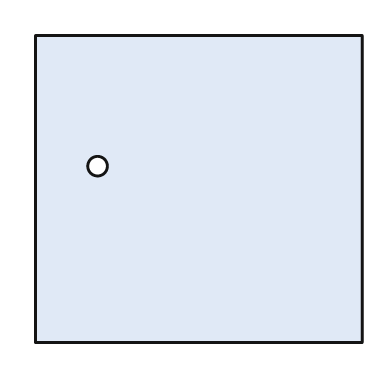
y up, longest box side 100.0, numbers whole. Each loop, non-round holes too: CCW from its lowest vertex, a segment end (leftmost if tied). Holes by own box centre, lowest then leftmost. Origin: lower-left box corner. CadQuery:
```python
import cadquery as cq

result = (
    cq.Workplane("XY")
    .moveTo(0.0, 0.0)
    .lineTo(100.0, 0.0)
    .lineTo(100.0, 94.0)
    .lineTo(0.0, 94.0)
    .close()
    .moveTo(19.0, 54.0)
    .circle(3.0)
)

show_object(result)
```